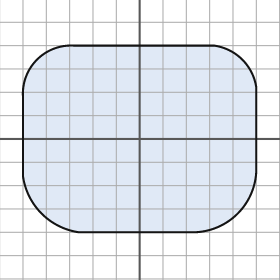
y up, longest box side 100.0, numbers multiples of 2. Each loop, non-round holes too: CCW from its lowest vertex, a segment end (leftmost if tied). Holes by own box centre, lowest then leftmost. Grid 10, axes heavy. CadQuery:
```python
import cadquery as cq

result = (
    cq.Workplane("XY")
    .moveTo(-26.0, -40.0)
    .lineTo(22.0, -40.0)
    .threePointArc((42.0, -32.0), (50.0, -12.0))
    .lineTo(50.0, 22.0)
    .threePointArc((44.0, 34.0), (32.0, 40.0))
    .lineTo(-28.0, 40.0)
    .threePointArc((-44.0, 34.0), (-50.0, 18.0))
    .lineTo(-50.0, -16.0)
    .threePointArc((-42.0, -32.0), (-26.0, -40.0))
    .close()
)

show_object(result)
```